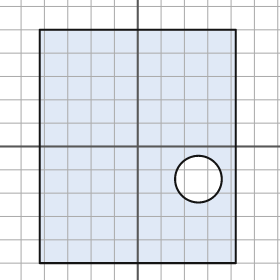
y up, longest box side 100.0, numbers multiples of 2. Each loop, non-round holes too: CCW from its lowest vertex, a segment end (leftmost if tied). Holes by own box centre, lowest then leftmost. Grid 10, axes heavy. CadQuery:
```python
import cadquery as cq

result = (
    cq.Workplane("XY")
    .moveTo(-42.0, -50.0)
    .lineTo(42.0, -50.0)
    .lineTo(42.0, 50.0)
    .lineTo(-42.0, 50.0)
    .close()
    .moveTo(26.0, -14.0)
    .circle(10.0)
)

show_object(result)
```